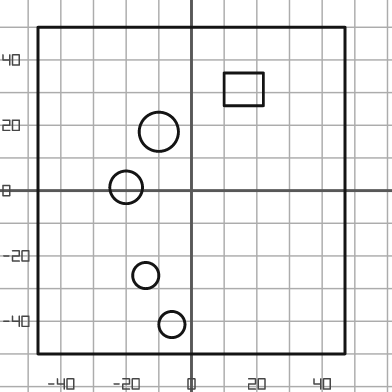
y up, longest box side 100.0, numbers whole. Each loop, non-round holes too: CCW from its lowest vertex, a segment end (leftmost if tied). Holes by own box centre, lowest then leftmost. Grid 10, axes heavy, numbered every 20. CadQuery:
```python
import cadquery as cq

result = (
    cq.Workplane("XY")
    .moveTo(-47.0, -50.0)
    .lineTo(47.0, -50.0)
    .lineTo(47.0, 50.0)
    .lineTo(-47.0, 50.0)
    .close()
    .moveTo(-6.0, -41.0)
    .circle(4.0)
    .moveTo(-14.0, -26.0)
    .circle(4.0)
    .moveTo(-20.0, 1.0)
    .circle(5.0)
    .moveTo(-10.0, 18.0)
    .circle(6.0)
    .moveTo(10.0, 26.0)
    .lineTo(22.0, 26.0)
    .lineTo(22.0, 36.0)
    .lineTo(10.0, 36.0)
    .close()
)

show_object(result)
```